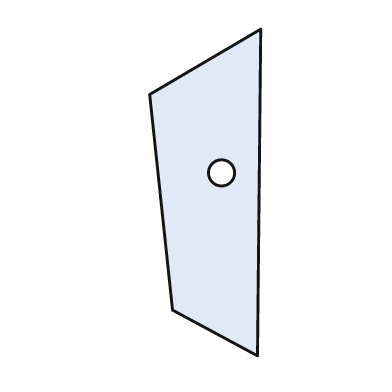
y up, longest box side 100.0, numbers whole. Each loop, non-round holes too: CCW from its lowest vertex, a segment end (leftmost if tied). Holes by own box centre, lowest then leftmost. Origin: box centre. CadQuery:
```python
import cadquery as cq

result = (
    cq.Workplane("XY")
    .moveTo(16.0, -50.0)
    .lineTo(17.0, 50.0)
    .lineTo(-17.0, 30.0)
    .lineTo(-10.0, -36.0)
    .close()
    .moveTo(5.0, 6.0)
    .circle(4.0)
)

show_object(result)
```